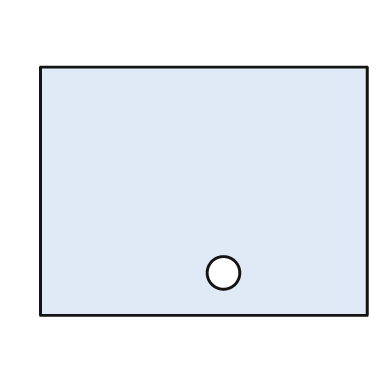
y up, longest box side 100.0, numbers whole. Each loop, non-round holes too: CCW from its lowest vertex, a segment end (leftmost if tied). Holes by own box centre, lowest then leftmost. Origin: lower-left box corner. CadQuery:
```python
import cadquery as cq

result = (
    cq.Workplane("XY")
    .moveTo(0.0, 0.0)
    .lineTo(100.0, 0.0)
    .lineTo(100.0, 76.0)
    .lineTo(0.0, 76.0)
    .close()
    .moveTo(56.0, 13.0)
    .circle(5.0)
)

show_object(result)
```